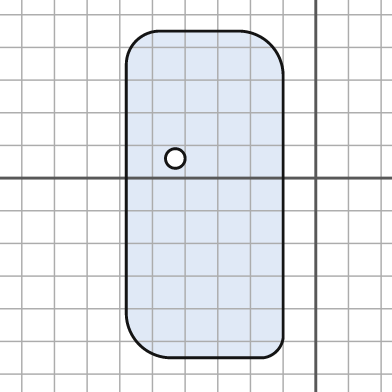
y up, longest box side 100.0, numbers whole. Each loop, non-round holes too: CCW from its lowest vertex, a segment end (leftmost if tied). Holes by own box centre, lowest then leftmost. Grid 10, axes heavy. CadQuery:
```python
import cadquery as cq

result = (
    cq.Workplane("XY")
    .moveTo(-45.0, -55.0)
    .lineTo(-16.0, -55.0)
    .threePointArc((-12.0, -53.0), (-10.0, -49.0))
    .lineTo(-10.0, 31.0)
    .threePointArc((-14.0, 41.0), (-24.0, 45.0))
    .lineTo(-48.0, 45.0)
    .threePointArc((-55.0, 42.0), (-58.0, 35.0))
    .lineTo(-58.0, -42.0)
    .threePointArc((-54.0, -51.0), (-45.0, -55.0))
    .close()
    .moveTo(-43.0, 6.0)
    .circle(3.0)
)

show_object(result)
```